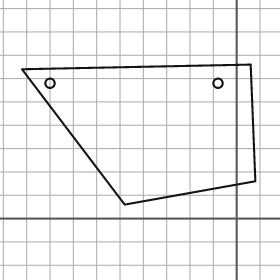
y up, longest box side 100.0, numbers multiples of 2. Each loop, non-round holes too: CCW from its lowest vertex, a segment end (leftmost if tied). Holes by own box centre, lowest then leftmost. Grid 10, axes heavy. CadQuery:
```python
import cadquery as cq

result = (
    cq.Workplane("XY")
    .moveTo(-48.0, 6.0)
    .lineTo(8.0, 16.0)
    .lineTo(6.0, 66.0)
    .lineTo(-92.0, 64.0)
    .close()
    .moveTo(-80.0, 58.0)
    .circle(2.0)
    .moveTo(-8.0, 58.0)
    .circle(2.0)
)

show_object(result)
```